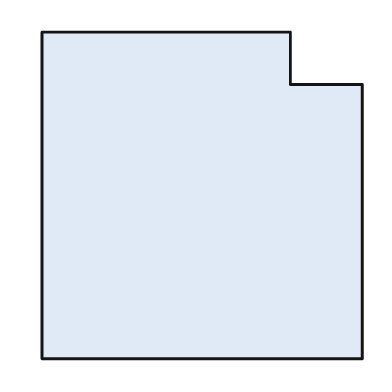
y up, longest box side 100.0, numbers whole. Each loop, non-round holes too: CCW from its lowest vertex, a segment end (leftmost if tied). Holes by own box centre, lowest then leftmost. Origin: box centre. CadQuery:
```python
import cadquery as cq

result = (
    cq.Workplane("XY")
    .moveTo(-49.0, -50.0)
    .lineTo(49.0, -50.0)
    .lineTo(49.0, 34.0)
    .lineTo(27.0, 34.0)
    .lineTo(27.0, 50.0)
    .lineTo(-49.0, 50.0)
    .close()
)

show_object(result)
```